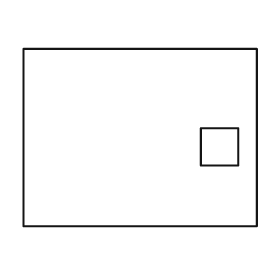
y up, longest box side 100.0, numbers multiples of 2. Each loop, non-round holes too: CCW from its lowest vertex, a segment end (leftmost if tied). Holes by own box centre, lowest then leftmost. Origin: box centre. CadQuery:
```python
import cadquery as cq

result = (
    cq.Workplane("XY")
    .moveTo(-50.0, -38.0)
    .lineTo(50.0, -38.0)
    .lineTo(50.0, 38.0)
    .lineTo(-50.0, 38.0)
    .close()
    .moveTo(26.0, -12.0)
    .lineTo(42.0, -12.0)
    .lineTo(42.0, 4.0)
    .lineTo(26.0, 4.0)
    .close()
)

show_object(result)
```